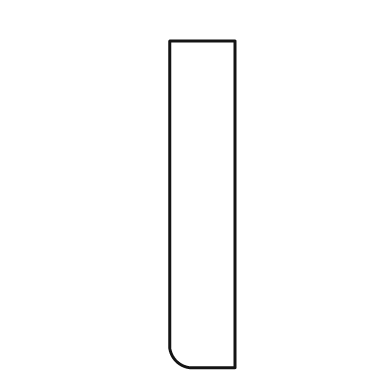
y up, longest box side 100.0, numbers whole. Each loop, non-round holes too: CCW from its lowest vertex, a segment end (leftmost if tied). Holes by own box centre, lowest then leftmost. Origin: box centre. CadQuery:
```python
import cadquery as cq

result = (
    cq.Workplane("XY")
    .moveTo(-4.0, -50.0)
    .lineTo(10.0, -50.0)
    .lineTo(10.0, 50.0)
    .lineTo(-10.0, 50.0)
    .lineTo(-10.0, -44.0)
    .threePointArc((-8.0, -48.0), (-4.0, -50.0))
    .close()
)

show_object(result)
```